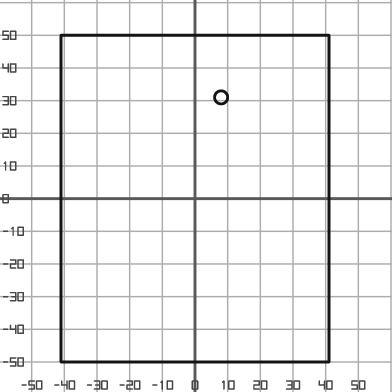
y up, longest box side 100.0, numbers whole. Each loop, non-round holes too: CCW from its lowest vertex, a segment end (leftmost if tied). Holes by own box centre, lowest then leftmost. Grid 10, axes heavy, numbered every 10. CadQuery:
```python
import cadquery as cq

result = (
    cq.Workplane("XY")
    .moveTo(-41.0, -50.0)
    .lineTo(41.0, -50.0)
    .lineTo(41.0, 50.0)
    .lineTo(-41.0, 50.0)
    .close()
    .moveTo(8.0, 31.0)
    .circle(2.0)
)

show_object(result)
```